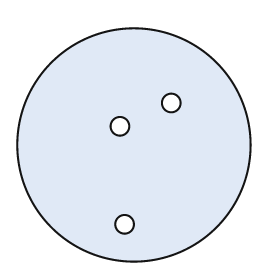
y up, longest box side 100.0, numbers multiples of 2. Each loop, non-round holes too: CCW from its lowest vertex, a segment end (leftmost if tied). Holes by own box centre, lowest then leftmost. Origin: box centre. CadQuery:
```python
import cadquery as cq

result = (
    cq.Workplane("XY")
    .moveTo(0.0, 0.0)
    .circle(50.0)
    .moveTo(-4.0, -34.0)
    .circle(4.0)
    .moveTo(-6.0, 8.0)
    .circle(4.0)
    .moveTo(16.0, 18.0)
    .circle(4.0)
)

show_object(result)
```